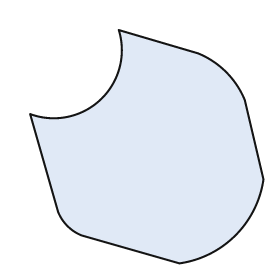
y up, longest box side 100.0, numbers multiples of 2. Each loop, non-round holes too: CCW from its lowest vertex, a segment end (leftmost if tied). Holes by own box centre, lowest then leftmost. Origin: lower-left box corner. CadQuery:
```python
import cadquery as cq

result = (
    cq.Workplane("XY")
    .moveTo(64.0, 0.0)
    .threePointArc((88.0, 12.0), (100.0, 36.0))
    .lineTo(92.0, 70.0)
    .threePointArc((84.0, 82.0), (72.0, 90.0))
    .lineTo(38.0, 100.0)
    .threePointArc((30.0, 70.0), (0.0, 64.0))
    .lineTo(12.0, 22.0)
    .threePointArc((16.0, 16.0), (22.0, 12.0))
    .close()
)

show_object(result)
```